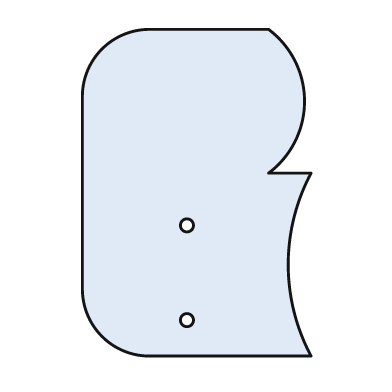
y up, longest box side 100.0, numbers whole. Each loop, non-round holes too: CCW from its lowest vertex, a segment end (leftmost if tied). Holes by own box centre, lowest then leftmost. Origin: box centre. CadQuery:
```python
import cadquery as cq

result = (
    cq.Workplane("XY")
    .moveTo(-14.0, -50.0)
    .lineTo(35.0, -50.0)
    .threePointArc((28.0, -22.0), (35.0, 6.0))
    .lineTo(22.0, 6.0)
    .threePointArc((33.0, 28.0), (22.0, 50.0))
    .lineTo(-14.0, 50.0)
    .threePointArc((-29.0, 44.0), (-35.0, 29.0))
    .lineTo(-35.0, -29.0)
    .threePointArc((-29.0, -44.0), (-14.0, -50.0))
    .close()
    .moveTo(-3.0, -39.0)
    .circle(2.0)
    .moveTo(-3.0, -10.0)
    .circle(2.0)
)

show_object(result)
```